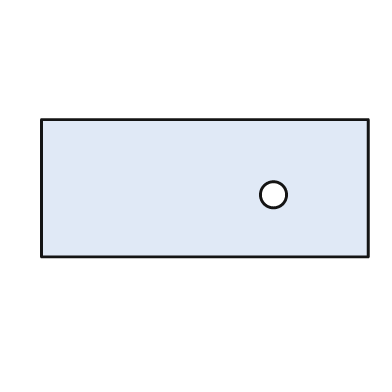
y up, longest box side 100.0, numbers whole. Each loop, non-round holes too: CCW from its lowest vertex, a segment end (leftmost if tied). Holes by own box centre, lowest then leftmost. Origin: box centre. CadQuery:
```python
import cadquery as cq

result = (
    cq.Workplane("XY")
    .moveTo(-50.0, -21.0)
    .lineTo(50.0, -21.0)
    .lineTo(50.0, 21.0)
    .lineTo(-50.0, 21.0)
    .close()
    .moveTo(21.0, -2.0)
    .circle(4.0)
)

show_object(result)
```